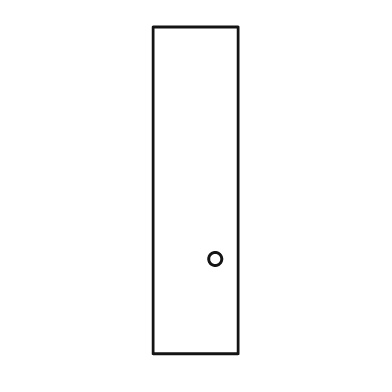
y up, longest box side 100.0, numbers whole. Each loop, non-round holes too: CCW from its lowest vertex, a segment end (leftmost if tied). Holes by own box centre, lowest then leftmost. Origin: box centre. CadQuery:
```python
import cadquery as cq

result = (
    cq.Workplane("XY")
    .moveTo(-13.0, -50.0)
    .lineTo(13.0, -50.0)
    .lineTo(13.0, 50.0)
    .lineTo(-13.0, 50.0)
    .close()
    .moveTo(6.0, -21.0)
    .circle(2.0)
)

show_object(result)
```